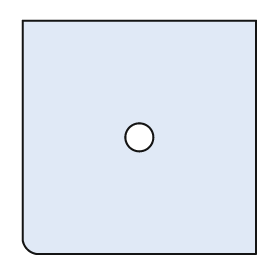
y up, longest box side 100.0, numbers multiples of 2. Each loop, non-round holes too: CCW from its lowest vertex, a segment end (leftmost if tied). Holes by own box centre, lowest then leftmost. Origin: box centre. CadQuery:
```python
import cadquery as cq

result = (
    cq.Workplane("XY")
    .moveTo(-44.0, -50.0)
    .lineTo(50.0, -50.0)
    .lineTo(50.0, 50.0)
    .lineTo(-50.0, 50.0)
    .lineTo(-50.0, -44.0)
    .threePointArc((-48.0, -48.0), (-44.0, -50.0))
    .close()
    .moveTo(0.0, 0.0)
    .circle(6.0)
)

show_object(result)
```